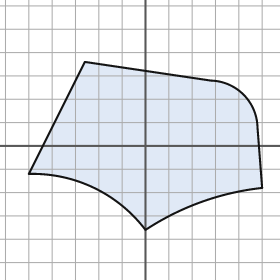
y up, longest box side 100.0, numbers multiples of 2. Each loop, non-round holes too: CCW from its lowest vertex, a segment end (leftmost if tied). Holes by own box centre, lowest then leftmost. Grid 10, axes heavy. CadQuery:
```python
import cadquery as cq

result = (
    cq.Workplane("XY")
    .moveTo(0.0, -36.0)
    .threePointArc((24.0, -24.0), (50.0, -18.0))
    .lineTo(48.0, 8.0)
    .threePointArc((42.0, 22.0), (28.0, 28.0))
    .lineTo(-26.0, 36.0)
    .lineTo(-50.0, -12.0)
    .threePointArc((-22.0, -18.0), (0.0, -36.0))
    .close()
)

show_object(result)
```